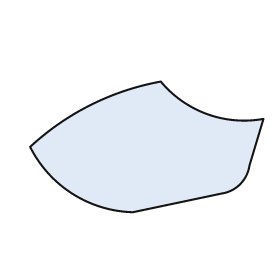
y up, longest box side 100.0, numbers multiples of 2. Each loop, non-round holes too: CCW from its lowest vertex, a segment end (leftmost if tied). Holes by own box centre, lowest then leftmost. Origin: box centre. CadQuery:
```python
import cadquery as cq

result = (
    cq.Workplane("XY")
    .moveTo(-6.0, -28.0)
    .lineTo(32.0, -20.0)
    .threePointArc((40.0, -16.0), (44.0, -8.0))
    .lineTo(50.0, 12.0)
    .threePointArc((26.0, 14.0), (6.0, 28.0))
    .threePointArc((-24.0, 18.0), (-50.0, 0.0))
    .threePointArc((-32.0, -20.0), (-6.0, -28.0))
    .close()
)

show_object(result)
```